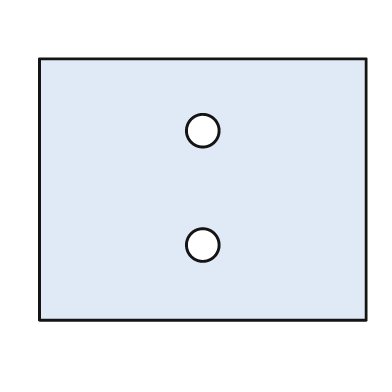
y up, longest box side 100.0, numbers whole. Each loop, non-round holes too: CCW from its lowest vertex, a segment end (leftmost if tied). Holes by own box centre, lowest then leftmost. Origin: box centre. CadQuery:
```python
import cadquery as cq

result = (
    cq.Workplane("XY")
    .moveTo(-50.0, -40.0)
    .lineTo(50.0, -40.0)
    .lineTo(50.0, 40.0)
    .lineTo(-50.0, 40.0)
    .close()
    .moveTo(0.0, -17.0)
    .circle(5.0)
    .moveTo(0.0, 18.0)
    .circle(5.0)
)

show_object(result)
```